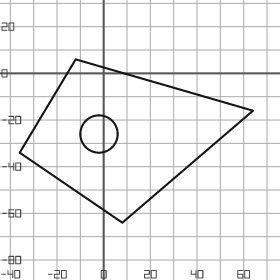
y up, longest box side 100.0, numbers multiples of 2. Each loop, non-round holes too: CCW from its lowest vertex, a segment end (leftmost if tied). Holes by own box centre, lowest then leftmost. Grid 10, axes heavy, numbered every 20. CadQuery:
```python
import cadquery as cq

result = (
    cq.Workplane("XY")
    .moveTo(8.0, -64.0)
    .lineTo(64.0, -16.0)
    .lineTo(-12.0, 6.0)
    .lineTo(-36.0, -34.0)
    .close()
    .moveTo(-2.0, -26.0)
    .circle(8.0)
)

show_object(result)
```